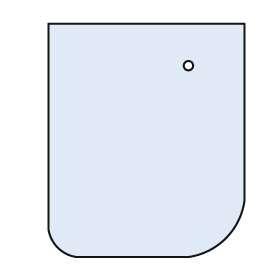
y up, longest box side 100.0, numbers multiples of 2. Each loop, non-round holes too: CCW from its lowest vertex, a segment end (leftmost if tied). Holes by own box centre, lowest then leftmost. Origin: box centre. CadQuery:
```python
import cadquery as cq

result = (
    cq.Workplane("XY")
    .moveTo(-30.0, -50.0)
    .lineTo(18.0, -50.0)
    .threePointArc((34.0, -42.0), (42.0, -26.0))
    .lineTo(42.0, 50.0)
    .lineTo(-42.0, 50.0)
    .lineTo(-42.0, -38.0)
    .threePointArc((-38.0, -46.0), (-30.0, -50.0))
    .close()
    .moveTo(18.0, 32.0)
    .circle(2.0)
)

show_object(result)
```